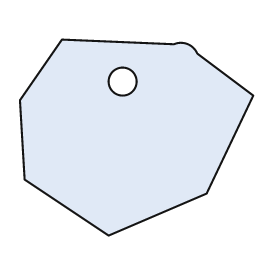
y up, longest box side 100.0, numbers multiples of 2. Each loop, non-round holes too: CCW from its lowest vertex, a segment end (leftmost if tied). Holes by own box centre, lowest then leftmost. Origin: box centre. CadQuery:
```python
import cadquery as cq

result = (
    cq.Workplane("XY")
    .moveTo(-12.0, -42.0)
    .lineTo(30.0, -24.0)
    .lineTo(50.0, 18.0)
    .lineTo(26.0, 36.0)
    .threePointArc((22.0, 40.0), (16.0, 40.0))
    .lineTo(-32.0, 42.0)
    .lineTo(-50.0, 16.0)
    .lineTo(-48.0, -18.0)
    .close()
    .moveTo(-6.0, 24.0)
    .circle(6.0)
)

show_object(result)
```